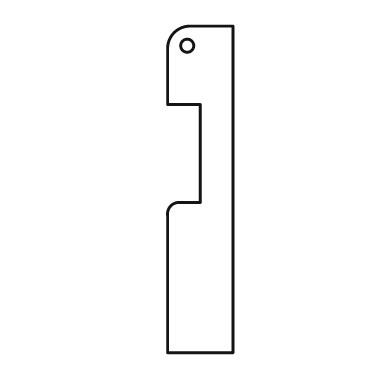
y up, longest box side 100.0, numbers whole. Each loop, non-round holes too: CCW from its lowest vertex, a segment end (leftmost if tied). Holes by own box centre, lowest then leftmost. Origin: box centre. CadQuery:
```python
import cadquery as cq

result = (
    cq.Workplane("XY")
    .moveTo(-10.0, -50.0)
    .lineTo(10.0, -50.0)
    .lineTo(10.0, 50.0)
    .lineTo(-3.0, 50.0)
    .threePointArc((-8.0, 48.0), (-10.0, 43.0))
    .lineTo(-10.0, 26.0)
    .lineTo(0.0, 26.0)
    .lineTo(0.0, -4.0)
    .lineTo(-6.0, -4.0)
    .threePointArc((-9.0, -5.0), (-10.0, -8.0))
    .close()
    .moveTo(-4.0, 44.0)
    .circle(2.0)
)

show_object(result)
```